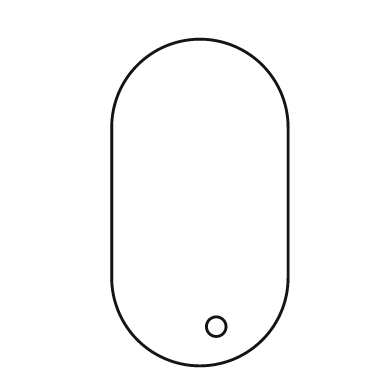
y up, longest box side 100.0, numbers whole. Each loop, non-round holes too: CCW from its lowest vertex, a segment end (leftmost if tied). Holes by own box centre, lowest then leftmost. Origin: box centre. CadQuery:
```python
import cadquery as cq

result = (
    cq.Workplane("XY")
    .moveTo(-27.0, -23.0)
    .threePointArc((0.0, -50.0), (27.0, -23.0))
    .lineTo(27.0, 23.0)
    .threePointArc((0.0, 50.0), (-27.0, 23.0))
    .close()
    .moveTo(5.0, -38.0)
    .circle(3.0)
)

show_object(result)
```